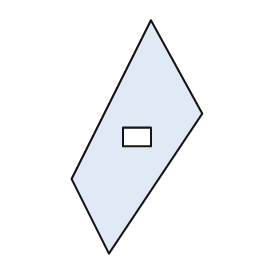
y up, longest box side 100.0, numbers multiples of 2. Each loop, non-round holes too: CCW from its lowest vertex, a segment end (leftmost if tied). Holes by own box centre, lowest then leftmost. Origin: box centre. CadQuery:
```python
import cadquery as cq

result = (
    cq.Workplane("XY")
    .moveTo(-12.0, -50.0)
    .lineTo(28.0, 10.0)
    .lineTo(6.0, 50.0)
    .lineTo(-28.0, -18.0)
    .close()
    .moveTo(-6.0, -4.0)
    .lineTo(6.0, -4.0)
    .lineTo(6.0, 4.0)
    .lineTo(-6.0, 4.0)
    .close()
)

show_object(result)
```